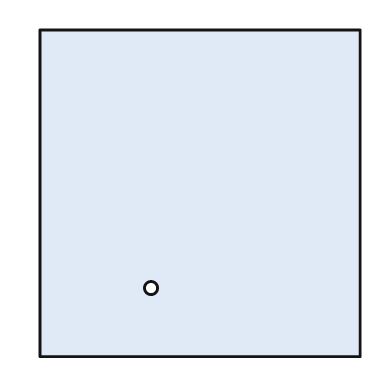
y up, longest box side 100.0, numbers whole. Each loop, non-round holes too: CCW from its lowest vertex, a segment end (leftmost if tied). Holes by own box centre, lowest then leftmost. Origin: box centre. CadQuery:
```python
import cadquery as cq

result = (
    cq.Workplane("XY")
    .moveTo(-49.0, -50.0)
    .lineTo(49.0, -50.0)
    .lineTo(49.0, 50.0)
    .lineTo(-49.0, 50.0)
    .close()
    .moveTo(-15.0, -29.0)
    .circle(2.0)
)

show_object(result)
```